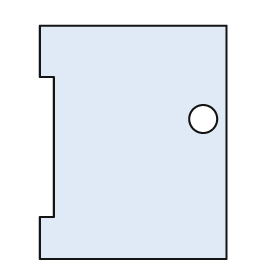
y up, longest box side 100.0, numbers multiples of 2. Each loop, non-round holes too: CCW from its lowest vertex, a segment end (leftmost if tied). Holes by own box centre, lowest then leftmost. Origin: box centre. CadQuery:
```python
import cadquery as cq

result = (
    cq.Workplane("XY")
    .moveTo(-40.0, -50.0)
    .lineTo(40.0, -50.0)
    .lineTo(40.0, 50.0)
    .lineTo(-40.0, 50.0)
    .lineTo(-40.0, 28.0)
    .lineTo(-34.0, 28.0)
    .lineTo(-34.0, -32.0)
    .lineTo(-40.0, -32.0)
    .close()
    .moveTo(30.0, 10.0)
    .circle(6.0)
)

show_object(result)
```